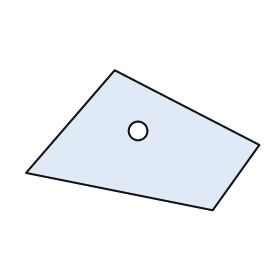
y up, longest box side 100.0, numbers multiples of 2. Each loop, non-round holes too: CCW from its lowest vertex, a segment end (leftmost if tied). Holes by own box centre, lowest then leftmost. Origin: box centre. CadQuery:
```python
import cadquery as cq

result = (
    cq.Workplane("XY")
    .moveTo(30.0, -30.0)
    .lineTo(50.0, -2.0)
    .lineTo(-12.0, 30.0)
    .lineTo(-50.0, -14.0)
    .close()
    .moveTo(-2.0, 4.0)
    .circle(4.0)
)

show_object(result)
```